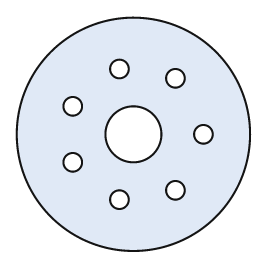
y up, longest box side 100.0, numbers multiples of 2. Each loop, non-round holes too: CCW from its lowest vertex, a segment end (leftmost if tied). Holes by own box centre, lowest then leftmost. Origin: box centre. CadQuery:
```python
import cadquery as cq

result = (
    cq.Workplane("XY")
    .moveTo(0.0, 0.0)
    .circle(50.0)
    .moveTo(-6.0, -28.0)
    .circle(4.0)
    .moveTo(18.0, -24.0)
    .circle(4.0)
    .moveTo(-26.0, -12.0)
    .circle(4.0)
    .moveTo(0.0, 0.0)
    .circle(12.0)
    .moveTo(30.0, 0.0)
    .circle(4.0)
    .moveTo(-26.0, 12.0)
    .circle(4.0)
    .moveTo(18.0, 24.0)
    .circle(4.0)
    .moveTo(-6.0, 28.0)
    .circle(4.0)
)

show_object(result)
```